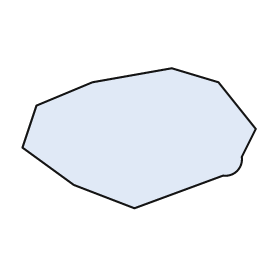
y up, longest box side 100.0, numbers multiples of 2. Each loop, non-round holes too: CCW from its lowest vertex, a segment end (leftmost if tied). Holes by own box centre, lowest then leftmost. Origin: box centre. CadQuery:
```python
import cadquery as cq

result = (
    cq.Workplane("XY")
    .moveTo(-2.0, -30.0)
    .lineTo(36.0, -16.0)
    .threePointArc((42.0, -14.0), (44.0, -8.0))
    .lineTo(50.0, 4.0)
    .lineTo(34.0, 24.0)
    .lineTo(14.0, 30.0)
    .lineTo(-20.0, 24.0)
    .lineTo(-44.0, 14.0)
    .lineTo(-50.0, -4.0)
    .lineTo(-28.0, -20.0)
    .close()
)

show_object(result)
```